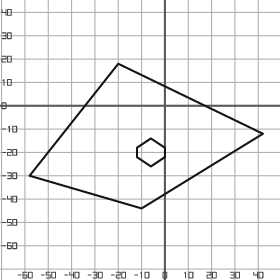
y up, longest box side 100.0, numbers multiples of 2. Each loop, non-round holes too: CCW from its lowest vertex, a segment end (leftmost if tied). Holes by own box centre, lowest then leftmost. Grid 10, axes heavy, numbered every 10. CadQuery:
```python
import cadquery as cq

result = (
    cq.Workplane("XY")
    .moveTo(-10.0, -44.0)
    .lineTo(42.0, -12.0)
    .lineTo(-20.0, 18.0)
    .lineTo(-58.0, -30.0)
    .close()
    .moveTo(-6.0, -26.0)
    .lineTo(0.0, -22.0)
    .lineTo(0.0, -18.0)
    .lineTo(-6.0, -14.0)
    .lineTo(-12.0, -18.0)
    .lineTo(-12.0, -22.0)
    .close()
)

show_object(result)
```